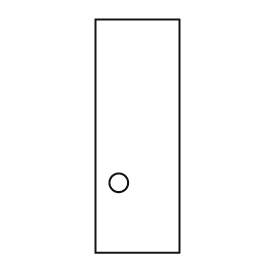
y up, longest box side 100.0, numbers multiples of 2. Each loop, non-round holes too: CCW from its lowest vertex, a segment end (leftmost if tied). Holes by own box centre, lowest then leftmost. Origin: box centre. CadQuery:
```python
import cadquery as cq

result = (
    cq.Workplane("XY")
    .moveTo(-18.0, -50.0)
    .lineTo(18.0, -50.0)
    .lineTo(18.0, 50.0)
    .lineTo(-18.0, 50.0)
    .close()
    .moveTo(-8.0, -20.0)
    .circle(4.0)
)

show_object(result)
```